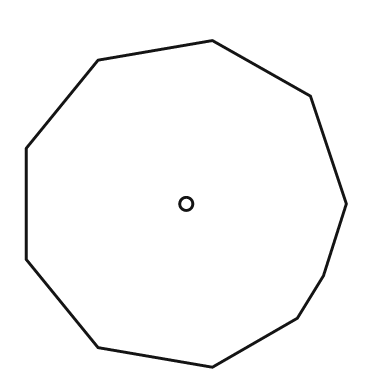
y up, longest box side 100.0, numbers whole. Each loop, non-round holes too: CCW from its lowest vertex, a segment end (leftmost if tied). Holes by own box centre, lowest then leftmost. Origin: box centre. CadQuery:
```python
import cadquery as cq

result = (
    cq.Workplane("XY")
    .moveTo(8.0, -50.0)
    .lineTo(34.0, -35.0)
    .lineTo(42.0, -22.0)
    .lineTo(49.0, 0.0)
    .lineTo(38.0, 33.0)
    .lineTo(8.0, 50.0)
    .lineTo(-27.0, 44.0)
    .lineTo(-49.0, 17.0)
    .lineTo(-49.0, -17.0)
    .lineTo(-27.0, -44.0)
    .close()
    .moveTo(0.0, 0.0)
    .circle(2.0)
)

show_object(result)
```